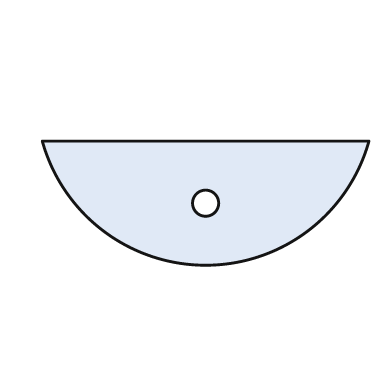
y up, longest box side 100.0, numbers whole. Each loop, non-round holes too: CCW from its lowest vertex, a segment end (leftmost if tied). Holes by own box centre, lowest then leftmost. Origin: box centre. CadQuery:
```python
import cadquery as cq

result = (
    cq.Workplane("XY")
    .moveTo(-50.0, 19.0)
    .threePointArc((0.0, -19.0), (50.0, 19.0))
    .close()
    .moveTo(0.0, 0.0)
    .circle(4.0)
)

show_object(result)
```